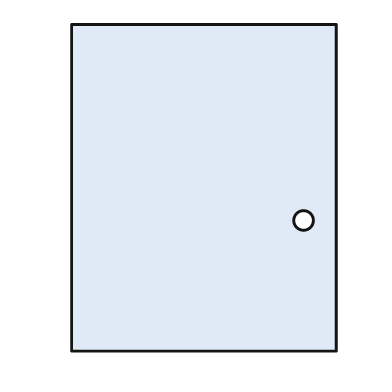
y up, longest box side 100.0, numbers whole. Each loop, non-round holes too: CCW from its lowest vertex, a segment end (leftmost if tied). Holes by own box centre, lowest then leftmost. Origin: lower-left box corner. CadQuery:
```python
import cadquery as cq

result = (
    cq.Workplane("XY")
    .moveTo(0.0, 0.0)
    .lineTo(81.0, 0.0)
    .lineTo(81.0, 100.0)
    .lineTo(0.0, 100.0)
    .close()
    .moveTo(71.0, 40.0)
    .circle(3.0)
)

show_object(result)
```